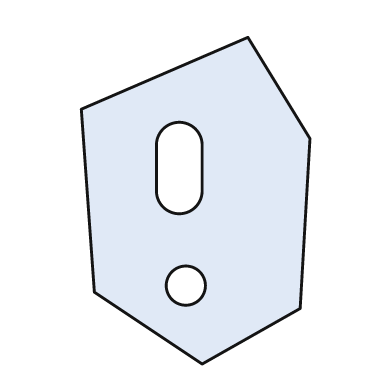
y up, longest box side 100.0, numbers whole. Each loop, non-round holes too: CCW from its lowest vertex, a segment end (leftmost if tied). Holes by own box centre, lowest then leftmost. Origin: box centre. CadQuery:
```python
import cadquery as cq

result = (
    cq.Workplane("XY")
    .moveTo(2.0, -50.0)
    .lineTo(32.0, -33.0)
    .lineTo(35.0, 19.0)
    .lineTo(16.0, 50.0)
    .lineTo(-35.0, 28.0)
    .lineTo(-31.0, -28.0)
    .close()
    .moveTo(-3.0, -26.0)
    .circle(6.0)
    .moveTo(-12.0, 3.0)
    .threePointArc((-5.0, -4.0), (2.0, 3.0))
    .lineTo(2.0, 17.0)
    .threePointArc((-5.0, 24.0), (-12.0, 17.0))
    .close()
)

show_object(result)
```